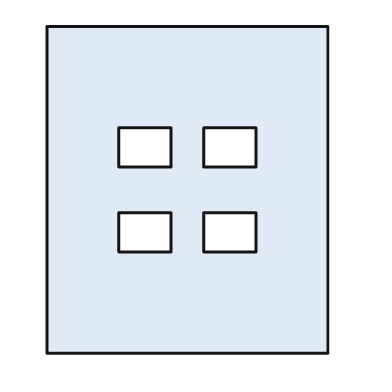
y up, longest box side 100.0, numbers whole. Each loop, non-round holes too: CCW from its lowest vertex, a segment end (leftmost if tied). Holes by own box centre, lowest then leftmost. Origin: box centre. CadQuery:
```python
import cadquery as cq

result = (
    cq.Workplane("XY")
    .moveTo(-43.0, -50.0)
    .lineTo(43.0, -50.0)
    .lineTo(43.0, 50.0)
    .lineTo(-43.0, 50.0)
    .close()
    .moveTo(-21.0, -19.0)
    .lineTo(-5.0, -19.0)
    .lineTo(-5.0, -7.0)
    .lineTo(-21.0, -7.0)
    .close()
    .moveTo(5.0, -19.0)
    .lineTo(21.0, -19.0)
    .lineTo(21.0, -7.0)
    .lineTo(5.0, -7.0)
    .close()
    .moveTo(-21.0, 7.0)
    .lineTo(-5.0, 7.0)
    .lineTo(-5.0, 19.0)
    .lineTo(-21.0, 19.0)
    .close()
    .moveTo(5.0, 7.0)
    .lineTo(21.0, 7.0)
    .lineTo(21.0, 19.0)
    .lineTo(5.0, 19.0)
    .close()
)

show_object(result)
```